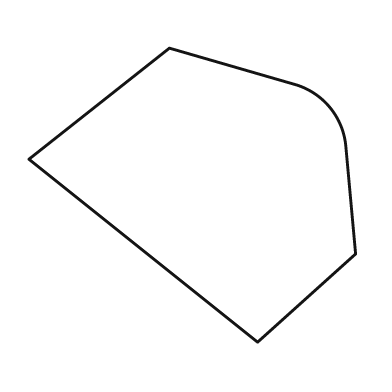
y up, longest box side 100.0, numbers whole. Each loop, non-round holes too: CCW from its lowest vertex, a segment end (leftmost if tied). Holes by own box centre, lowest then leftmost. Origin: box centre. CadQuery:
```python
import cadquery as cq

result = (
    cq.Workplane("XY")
    .moveTo(20.0, -45.0)
    .lineTo(50.0, -18.0)
    .lineTo(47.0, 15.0)
    .threePointArc((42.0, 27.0), (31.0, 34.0))
    .lineTo(-7.0, 45.0)
    .lineTo(-50.0, 11.0)
    .close()
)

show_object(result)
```